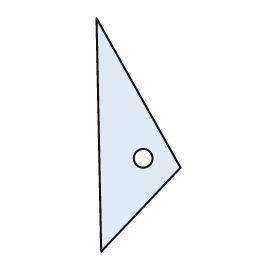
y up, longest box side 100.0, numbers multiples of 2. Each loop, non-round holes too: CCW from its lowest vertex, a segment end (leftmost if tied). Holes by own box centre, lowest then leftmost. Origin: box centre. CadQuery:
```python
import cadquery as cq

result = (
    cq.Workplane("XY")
    .moveTo(-16.0, -50.0)
    .lineTo(18.0, -14.0)
    .lineTo(-18.0, 50.0)
    .close()
    .moveTo(2.0, -10.0)
    .circle(4.0)
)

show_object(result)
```